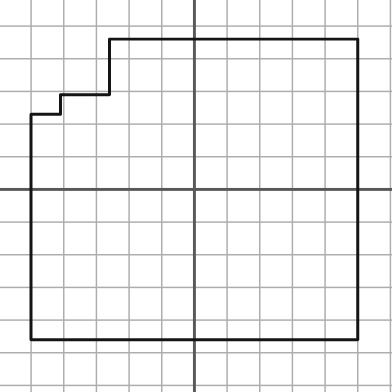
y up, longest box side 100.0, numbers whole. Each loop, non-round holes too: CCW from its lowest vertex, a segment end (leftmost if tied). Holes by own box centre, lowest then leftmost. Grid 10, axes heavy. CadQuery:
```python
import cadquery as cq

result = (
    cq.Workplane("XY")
    .moveTo(-50.0, -46.0)
    .lineTo(50.0, -46.0)
    .lineTo(50.0, 46.0)
    .lineTo(-26.0, 46.0)
    .lineTo(-26.0, 29.0)
    .lineTo(-41.0, 29.0)
    .lineTo(-41.0, 23.0)
    .lineTo(-50.0, 23.0)
    .close()
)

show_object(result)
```